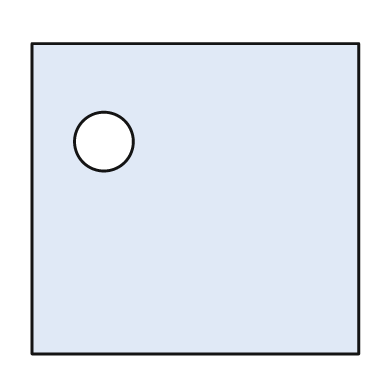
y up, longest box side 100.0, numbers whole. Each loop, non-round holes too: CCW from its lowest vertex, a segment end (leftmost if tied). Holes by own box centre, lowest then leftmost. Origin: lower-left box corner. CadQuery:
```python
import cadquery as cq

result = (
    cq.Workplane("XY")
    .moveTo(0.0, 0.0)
    .lineTo(100.0, 0.0)
    .lineTo(100.0, 95.0)
    .lineTo(0.0, 95.0)
    .close()
    .moveTo(22.0, 65.0)
    .circle(9.0)
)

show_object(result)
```